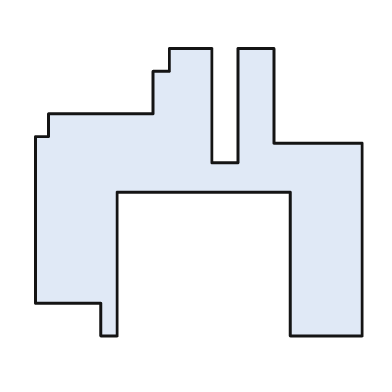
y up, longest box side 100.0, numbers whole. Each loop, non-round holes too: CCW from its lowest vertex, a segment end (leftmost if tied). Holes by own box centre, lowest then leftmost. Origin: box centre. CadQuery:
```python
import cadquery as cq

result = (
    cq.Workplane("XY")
    .moveTo(-30.0, -44.0)
    .lineTo(-25.0, -44.0)
    .lineTo(-25.0, 0.0)
    .lineTo(28.0, 0.0)
    .lineTo(28.0, -44.0)
    .lineTo(50.0, -44.0)
    .lineTo(50.0, 15.0)
    .lineTo(23.0, 15.0)
    .lineTo(23.0, 44.0)
    .lineTo(12.0, 44.0)
    .lineTo(12.0, 9.0)
    .lineTo(4.0, 9.0)
    .lineTo(4.0, 44.0)
    .lineTo(-9.0, 44.0)
    .lineTo(-9.0, 37.0)
    .lineTo(-14.0, 37.0)
    .lineTo(-14.0, 24.0)
    .lineTo(-46.0, 24.0)
    .lineTo(-46.0, 17.0)
    .lineTo(-50.0, 17.0)
    .lineTo(-50.0, -34.0)
    .lineTo(-30.0, -34.0)
    .close()
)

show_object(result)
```